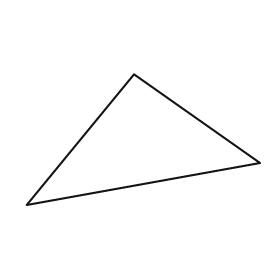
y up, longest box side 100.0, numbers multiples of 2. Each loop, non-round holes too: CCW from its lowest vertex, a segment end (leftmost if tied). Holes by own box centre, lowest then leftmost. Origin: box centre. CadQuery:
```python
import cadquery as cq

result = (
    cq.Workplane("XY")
    .moveTo(-50.0, -28.0)
    .lineTo(50.0, -10.0)
    .lineTo(-4.0, 28.0)
    .close()
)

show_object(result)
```